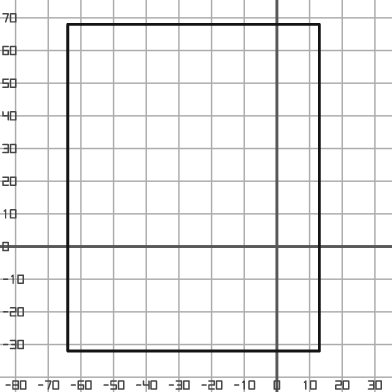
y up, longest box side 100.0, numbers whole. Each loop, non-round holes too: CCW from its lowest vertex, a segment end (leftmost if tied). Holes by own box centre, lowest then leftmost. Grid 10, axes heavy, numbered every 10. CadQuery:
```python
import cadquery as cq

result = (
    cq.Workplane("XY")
    .moveTo(-64.0, -32.0)
    .lineTo(13.0, -32.0)
    .lineTo(13.0, 68.0)
    .lineTo(-64.0, 68.0)
    .close()
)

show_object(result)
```